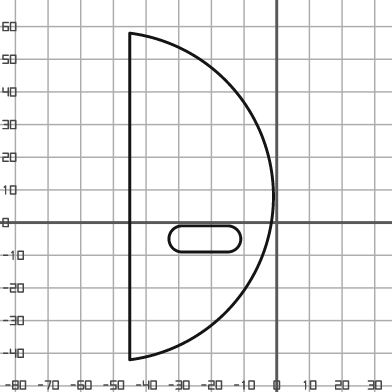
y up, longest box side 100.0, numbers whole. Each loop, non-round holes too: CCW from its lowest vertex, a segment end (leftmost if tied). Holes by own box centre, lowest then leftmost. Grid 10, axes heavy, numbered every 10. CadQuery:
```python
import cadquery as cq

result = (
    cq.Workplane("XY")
    .moveTo(-45.0, -42.0)
    .threePointArc((-1.0, 8.0), (-45.0, 58.0))
    .close()
    .moveTo(-29.0, -9.0)
    .lineTo(-15.0, -9.0)
    .threePointArc((-11.0, -5.0), (-15.0, -1.0))
    .lineTo(-29.0, -1.0)
    .threePointArc((-33.0, -5.0), (-29.0, -9.0))
    .close()
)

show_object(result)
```